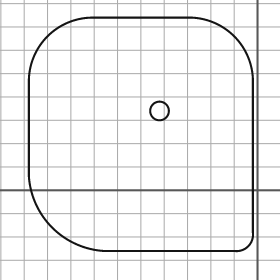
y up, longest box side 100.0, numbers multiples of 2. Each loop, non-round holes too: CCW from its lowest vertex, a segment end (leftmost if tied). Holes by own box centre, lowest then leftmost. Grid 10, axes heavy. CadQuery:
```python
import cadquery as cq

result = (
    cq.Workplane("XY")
    .moveTo(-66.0, -26.0)
    .lineTo(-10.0, -26.0)
    .threePointArc((-4.0, -24.0), (-2.0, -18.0))
    .lineTo(-2.0, 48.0)
    .threePointArc((-10.0, 66.0), (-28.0, 74.0))
    .lineTo(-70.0, 74.0)
    .threePointArc((-90.0, 66.0), (-98.0, 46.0))
    .lineTo(-98.0, 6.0)
    .threePointArc((-88.0, -16.0), (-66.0, -26.0))
    .close()
    .moveTo(-42.0, 34.0)
    .circle(4.0)
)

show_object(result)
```